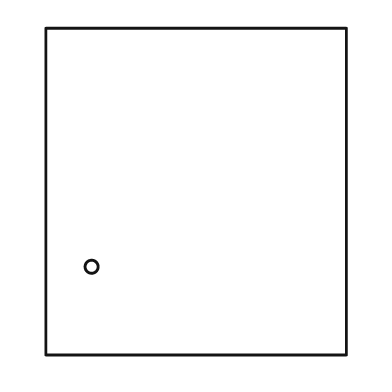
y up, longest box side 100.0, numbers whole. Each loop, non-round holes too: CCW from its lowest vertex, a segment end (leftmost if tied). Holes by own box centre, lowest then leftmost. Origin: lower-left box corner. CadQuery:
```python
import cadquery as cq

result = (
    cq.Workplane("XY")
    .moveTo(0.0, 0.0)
    .lineTo(92.0, 0.0)
    .lineTo(92.0, 100.0)
    .lineTo(0.0, 100.0)
    .close()
    .moveTo(14.0, 27.0)
    .circle(2.0)
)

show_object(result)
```